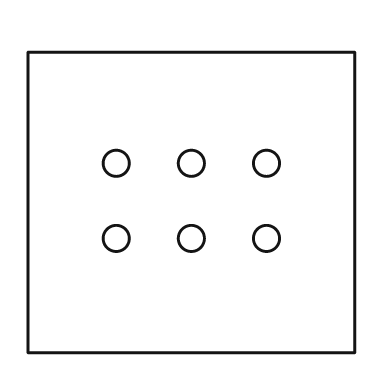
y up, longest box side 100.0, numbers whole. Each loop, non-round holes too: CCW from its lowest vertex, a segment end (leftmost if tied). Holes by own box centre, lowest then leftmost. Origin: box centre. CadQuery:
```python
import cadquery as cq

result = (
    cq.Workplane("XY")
    .moveTo(-50.0, -46.0)
    .lineTo(50.0, -46.0)
    .lineTo(50.0, 46.0)
    .lineTo(-50.0, 46.0)
    .close()
    .moveTo(-23.0, -11.0)
    .circle(4.0)
    .moveTo(0.0, -11.0)
    .circle(4.0)
    .moveTo(23.0, -11.0)
    .circle(4.0)
    .moveTo(-23.0, 12.0)
    .circle(4.0)
    .moveTo(0.0, 12.0)
    .circle(4.0)
    .moveTo(23.0, 12.0)
    .circle(4.0)
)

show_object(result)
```